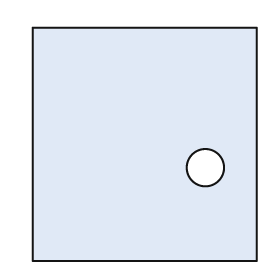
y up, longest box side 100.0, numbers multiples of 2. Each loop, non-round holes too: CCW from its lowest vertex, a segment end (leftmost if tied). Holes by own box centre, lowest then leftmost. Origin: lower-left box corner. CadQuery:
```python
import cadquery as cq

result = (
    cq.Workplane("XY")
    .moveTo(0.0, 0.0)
    .lineTo(96.0, 0.0)
    .lineTo(96.0, 100.0)
    .lineTo(0.0, 100.0)
    .close()
    .moveTo(74.0, 40.0)
    .circle(8.0)
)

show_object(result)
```